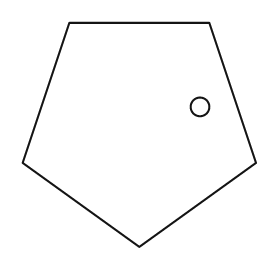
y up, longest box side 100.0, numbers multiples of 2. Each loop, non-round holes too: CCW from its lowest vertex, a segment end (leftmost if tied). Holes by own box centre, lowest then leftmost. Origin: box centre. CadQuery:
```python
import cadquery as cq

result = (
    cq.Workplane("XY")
    .moveTo(0.0, -48.0)
    .lineTo(50.0, -12.0)
    .lineTo(30.0, 48.0)
    .lineTo(-30.0, 48.0)
    .lineTo(-50.0, -12.0)
    .close()
    .moveTo(26.0, 12.0)
    .circle(4.0)
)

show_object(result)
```